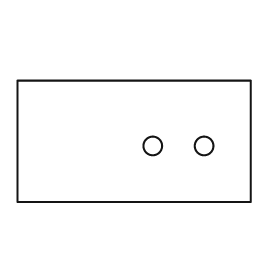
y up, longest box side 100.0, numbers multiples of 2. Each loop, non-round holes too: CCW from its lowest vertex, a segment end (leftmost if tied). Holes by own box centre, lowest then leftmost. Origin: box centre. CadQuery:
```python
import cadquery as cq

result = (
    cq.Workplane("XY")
    .moveTo(-50.0, -26.0)
    .lineTo(50.0, -26.0)
    .lineTo(50.0, 26.0)
    .lineTo(-50.0, 26.0)
    .close()
    .moveTo(8.0, -2.0)
    .circle(4.0)
    .moveTo(30.0, -2.0)
    .circle(4.0)
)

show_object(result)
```